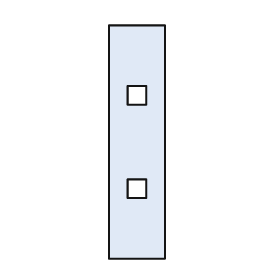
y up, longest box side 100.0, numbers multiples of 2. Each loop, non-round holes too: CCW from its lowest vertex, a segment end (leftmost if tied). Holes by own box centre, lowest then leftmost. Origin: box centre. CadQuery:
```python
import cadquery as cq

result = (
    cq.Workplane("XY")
    .moveTo(-12.0, -50.0)
    .lineTo(12.0, -50.0)
    .lineTo(12.0, 50.0)
    .lineTo(-12.0, 50.0)
    .close()
    .moveTo(-4.0, -24.0)
    .lineTo(4.0, -24.0)
    .lineTo(4.0, -16.0)
    .lineTo(-4.0, -16.0)
    .close()
    .moveTo(-4.0, 16.0)
    .lineTo(4.0, 16.0)
    .lineTo(4.0, 24.0)
    .lineTo(-4.0, 24.0)
    .close()
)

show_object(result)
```